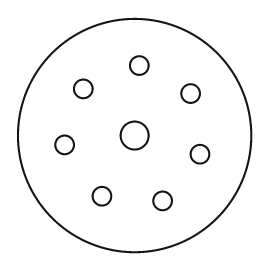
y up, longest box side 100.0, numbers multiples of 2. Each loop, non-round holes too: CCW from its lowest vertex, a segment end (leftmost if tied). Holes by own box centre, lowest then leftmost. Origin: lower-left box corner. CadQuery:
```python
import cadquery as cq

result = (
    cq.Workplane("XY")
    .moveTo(50.0, 50.0)
    .circle(50.0)
    .moveTo(62.0, 22.0)
    .circle(4.0)
    .moveTo(36.0, 24.0)
    .circle(4.0)
    .moveTo(78.0, 42.0)
    .circle(4.0)
    .moveTo(20.0, 46.0)
    .circle(4.0)
    .moveTo(50.0, 50.0)
    .circle(6.0)
    .moveTo(74.0, 68.0)
    .circle(4.0)
    .moveTo(28.0, 70.0)
    .circle(4.0)
    .moveTo(52.0, 80.0)
    .circle(4.0)
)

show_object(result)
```